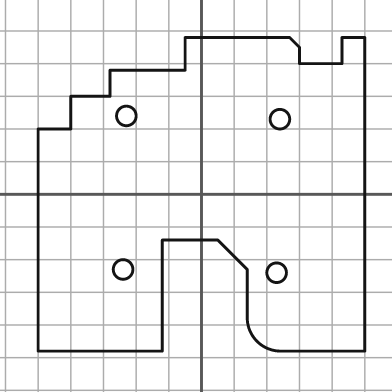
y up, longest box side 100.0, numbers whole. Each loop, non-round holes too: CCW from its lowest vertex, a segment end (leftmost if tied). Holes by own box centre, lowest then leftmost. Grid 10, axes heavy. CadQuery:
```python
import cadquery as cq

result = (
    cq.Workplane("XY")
    .moveTo(-50.0, -48.0)
    .lineTo(-12.0, -48.0)
    .lineTo(-12.0, -14.0)
    .lineTo(5.0, -14.0)
    .lineTo(14.0, -23.0)
    .lineTo(14.0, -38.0)
    .threePointArc((17.0, -45.0), (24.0, -48.0))
    .lineTo(50.0, -48.0)
    .lineTo(50.0, 48.0)
    .lineTo(43.0, 48.0)
    .lineTo(43.0, 40.0)
    .lineTo(30.0, 40.0)
    .lineTo(30.0, 45.0)
    .lineTo(27.0, 48.0)
    .lineTo(-5.0, 48.0)
    .lineTo(-5.0, 38.0)
    .lineTo(-28.0, 38.0)
    .lineTo(-28.0, 30.0)
    .lineTo(-40.0, 30.0)
    .lineTo(-40.0, 20.0)
    .lineTo(-50.0, 20.0)
    .close()
    .moveTo(23.0, -24.0)
    .circle(3.0)
    .moveTo(-24.0, -23.0)
    .circle(3.0)
    .moveTo(24.0, 23.0)
    .circle(3.0)
    .moveTo(-23.0, 24.0)
    .circle(3.0)
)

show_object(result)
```